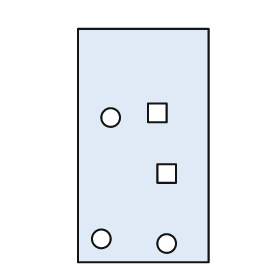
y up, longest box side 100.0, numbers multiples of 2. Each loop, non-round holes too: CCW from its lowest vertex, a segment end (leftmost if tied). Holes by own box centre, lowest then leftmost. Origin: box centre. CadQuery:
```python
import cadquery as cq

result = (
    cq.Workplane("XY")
    .moveTo(-28.0, -50.0)
    .lineTo(28.0, -50.0)
    .lineTo(28.0, 50.0)
    .lineTo(-28.0, 50.0)
    .close()
    .moveTo(10.0, -42.0)
    .circle(4.0)
    .moveTo(-18.0, -40.0)
    .circle(4.0)
    .moveTo(6.0, -16.0)
    .lineTo(14.0, -16.0)
    .lineTo(14.0, -8.0)
    .lineTo(6.0, -8.0)
    .close()
    .moveTo(-14.0, 12.0)
    .circle(4.0)
    .moveTo(2.0, 10.0)
    .lineTo(10.0, 10.0)
    .lineTo(10.0, 18.0)
    .lineTo(2.0, 18.0)
    .close()
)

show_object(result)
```